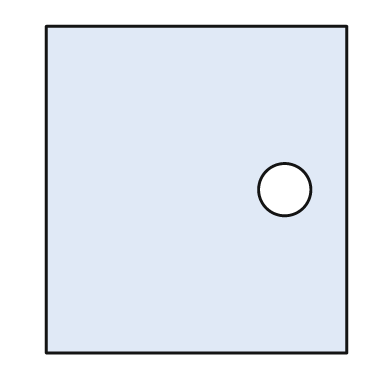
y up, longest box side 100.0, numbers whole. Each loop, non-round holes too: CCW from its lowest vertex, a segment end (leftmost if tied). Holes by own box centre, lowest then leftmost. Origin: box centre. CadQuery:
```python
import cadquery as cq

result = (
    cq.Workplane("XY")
    .moveTo(-46.0, -50.0)
    .lineTo(46.0, -50.0)
    .lineTo(46.0, 50.0)
    .lineTo(-46.0, 50.0)
    .close()
    .moveTo(27.0, 0.0)
    .circle(8.0)
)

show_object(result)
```